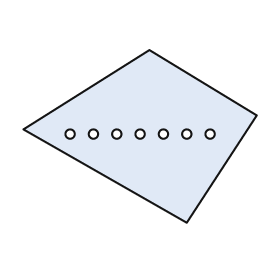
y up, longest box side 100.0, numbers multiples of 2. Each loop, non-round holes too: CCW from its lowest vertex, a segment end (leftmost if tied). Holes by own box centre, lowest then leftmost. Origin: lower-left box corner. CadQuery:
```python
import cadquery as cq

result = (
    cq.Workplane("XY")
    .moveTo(70.0, 0.0)
    .lineTo(100.0, 46.0)
    .lineTo(54.0, 74.0)
    .lineTo(0.0, 40.0)
    .close()
    .moveTo(20.0, 38.0)
    .circle(2.0)
    .moveTo(30.0, 38.0)
    .circle(2.0)
    .moveTo(40.0, 38.0)
    .circle(2.0)
    .moveTo(50.0, 38.0)
    .circle(2.0)
    .moveTo(60.0, 38.0)
    .circle(2.0)
    .moveTo(70.0, 38.0)
    .circle(2.0)
    .moveTo(80.0, 38.0)
    .circle(2.0)
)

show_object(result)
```